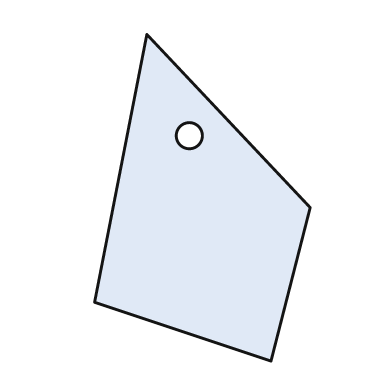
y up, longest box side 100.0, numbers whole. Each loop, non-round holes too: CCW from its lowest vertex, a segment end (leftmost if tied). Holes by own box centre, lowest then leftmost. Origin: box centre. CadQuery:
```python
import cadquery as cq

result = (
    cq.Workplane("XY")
    .moveTo(21.0, -50.0)
    .lineTo(33.0, -3.0)
    .lineTo(-17.0, 50.0)
    .lineTo(-33.0, -32.0)
    .close()
    .moveTo(-4.0, 19.0)
    .circle(4.0)
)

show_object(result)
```